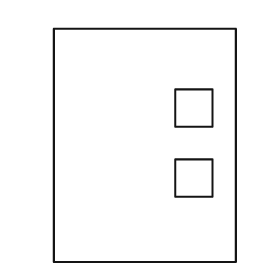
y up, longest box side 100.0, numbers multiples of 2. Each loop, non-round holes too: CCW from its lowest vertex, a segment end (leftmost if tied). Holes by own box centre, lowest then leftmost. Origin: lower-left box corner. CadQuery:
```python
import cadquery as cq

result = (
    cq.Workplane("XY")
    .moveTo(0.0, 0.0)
    .lineTo(78.0, 0.0)
    .lineTo(78.0, 100.0)
    .lineTo(0.0, 100.0)
    .close()
    .moveTo(52.0, 28.0)
    .lineTo(68.0, 28.0)
    .lineTo(68.0, 44.0)
    .lineTo(52.0, 44.0)
    .close()
    .moveTo(52.0, 58.0)
    .lineTo(68.0, 58.0)
    .lineTo(68.0, 74.0)
    .lineTo(52.0, 74.0)
    .close()
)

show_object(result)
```